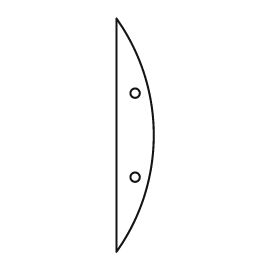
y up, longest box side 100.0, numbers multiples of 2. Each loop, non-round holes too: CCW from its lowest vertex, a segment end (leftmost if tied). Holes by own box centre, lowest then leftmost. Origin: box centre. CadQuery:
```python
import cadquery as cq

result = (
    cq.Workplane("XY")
    .moveTo(-8.0, -50.0)
    .threePointArc((8.0, 0.0), (-8.0, 50.0))
    .close()
    .moveTo(0.0, -18.0)
    .circle(2.0)
    .moveTo(0.0, 18.0)
    .circle(2.0)
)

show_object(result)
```